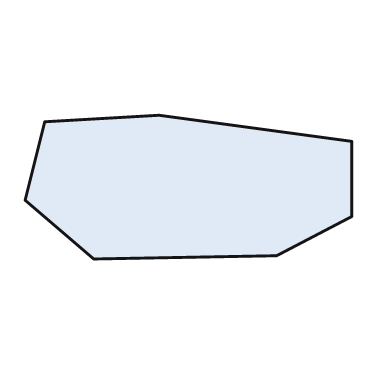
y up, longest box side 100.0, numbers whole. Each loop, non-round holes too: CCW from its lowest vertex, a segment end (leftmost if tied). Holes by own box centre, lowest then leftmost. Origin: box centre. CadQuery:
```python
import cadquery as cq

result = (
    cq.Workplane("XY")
    .moveTo(-29.0, -22.0)
    .lineTo(27.0, -21.0)
    .lineTo(50.0, -9.0)
    .lineTo(50.0, 14.0)
    .lineTo(-9.0, 22.0)
    .lineTo(-44.0, 20.0)
    .lineTo(-50.0, -4.0)
    .close()
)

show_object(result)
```